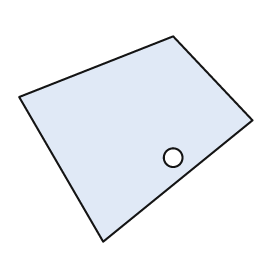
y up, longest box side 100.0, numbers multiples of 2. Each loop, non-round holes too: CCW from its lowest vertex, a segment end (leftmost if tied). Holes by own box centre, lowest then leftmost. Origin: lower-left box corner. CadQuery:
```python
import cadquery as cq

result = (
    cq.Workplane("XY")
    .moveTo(36.0, 0.0)
    .lineTo(100.0, 52.0)
    .lineTo(66.0, 88.0)
    .lineTo(0.0, 62.0)
    .close()
    .moveTo(66.0, 36.0)
    .circle(4.0)
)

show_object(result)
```